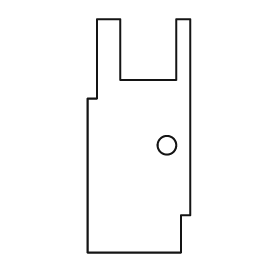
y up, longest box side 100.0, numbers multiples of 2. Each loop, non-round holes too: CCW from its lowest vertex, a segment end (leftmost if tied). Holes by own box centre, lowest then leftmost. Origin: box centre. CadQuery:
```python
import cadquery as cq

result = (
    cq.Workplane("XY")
    .moveTo(-22.0, -50.0)
    .lineTo(18.0, -50.0)
    .lineTo(18.0, -34.0)
    .lineTo(22.0, -34.0)
    .lineTo(22.0, 50.0)
    .lineTo(16.0, 50.0)
    .lineTo(16.0, 24.0)
    .lineTo(-8.0, 24.0)
    .lineTo(-8.0, 50.0)
    .lineTo(-18.0, 50.0)
    .lineTo(-18.0, 16.0)
    .lineTo(-22.0, 16.0)
    .close()
    .moveTo(12.0, -4.0)
    .circle(4.0)
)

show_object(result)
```